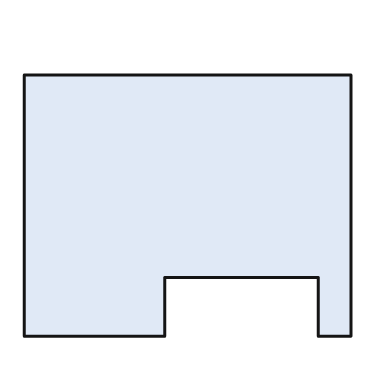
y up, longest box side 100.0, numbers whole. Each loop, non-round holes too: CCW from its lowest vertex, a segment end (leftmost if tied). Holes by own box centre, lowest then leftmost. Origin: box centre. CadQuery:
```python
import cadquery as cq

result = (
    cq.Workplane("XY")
    .moveTo(-50.0, -40.0)
    .lineTo(-7.0, -40.0)
    .lineTo(-7.0, -22.0)
    .lineTo(40.0, -22.0)
    .lineTo(40.0, -40.0)
    .lineTo(50.0, -40.0)
    .lineTo(50.0, 40.0)
    .lineTo(-50.0, 40.0)
    .close()
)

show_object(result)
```